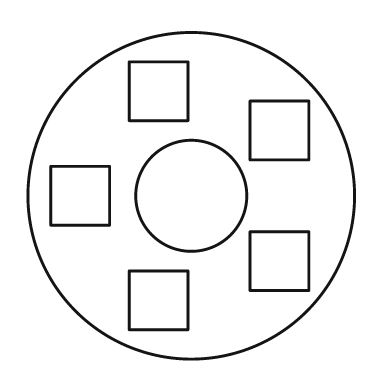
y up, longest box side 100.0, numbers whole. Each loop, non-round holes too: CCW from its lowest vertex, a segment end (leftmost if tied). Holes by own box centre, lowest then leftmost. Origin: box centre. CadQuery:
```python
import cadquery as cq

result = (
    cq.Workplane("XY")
    .moveTo(0.0, 0.0)
    .circle(50.0)
    .moveTo(-19.0, -41.0)
    .lineTo(-1.0, -41.0)
    .lineTo(-1.0, -23.0)
    .lineTo(-19.0, -23.0)
    .close()
    .moveTo(18.0, -29.0)
    .lineTo(36.0, -29.0)
    .lineTo(36.0, -11.0)
    .lineTo(18.0, -11.0)
    .close()
    .moveTo(-43.0, -9.0)
    .lineTo(-25.0, -9.0)
    .lineTo(-25.0, 9.0)
    .lineTo(-43.0, 9.0)
    .close()
    .moveTo(0.0, 0.0)
    .circle(17.0)
    .moveTo(18.0, 11.0)
    .lineTo(36.0, 11.0)
    .lineTo(36.0, 29.0)
    .lineTo(18.0, 29.0)
    .close()
    .moveTo(-19.0, 23.0)
    .lineTo(-1.0, 23.0)
    .lineTo(-1.0, 41.0)
    .lineTo(-19.0, 41.0)
    .close()
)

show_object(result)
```